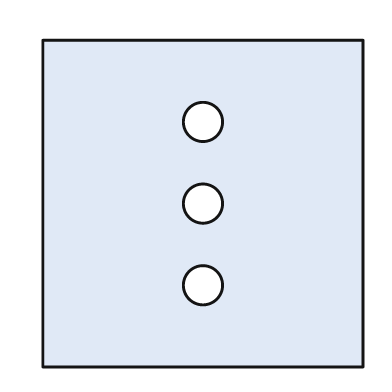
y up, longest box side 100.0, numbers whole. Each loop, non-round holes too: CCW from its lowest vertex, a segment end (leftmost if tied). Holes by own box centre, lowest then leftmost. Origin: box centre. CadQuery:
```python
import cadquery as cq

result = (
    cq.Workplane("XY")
    .moveTo(-49.0, -50.0)
    .lineTo(49.0, -50.0)
    .lineTo(49.0, 50.0)
    .lineTo(-49.0, 50.0)
    .close()
    .moveTo(0.0, -25.0)
    .circle(6.0)
    .moveTo(0.0, 0.0)
    .circle(6.0)
    .moveTo(0.0, 25.0)
    .circle(6.0)
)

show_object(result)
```